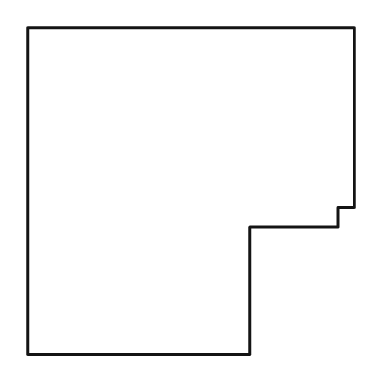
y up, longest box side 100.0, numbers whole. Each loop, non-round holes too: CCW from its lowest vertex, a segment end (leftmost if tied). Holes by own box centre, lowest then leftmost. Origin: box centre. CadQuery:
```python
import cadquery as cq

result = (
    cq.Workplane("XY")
    .moveTo(-50.0, -50.0)
    .lineTo(18.0, -50.0)
    .lineTo(18.0, -11.0)
    .lineTo(45.0, -11.0)
    .lineTo(45.0, -5.0)
    .lineTo(50.0, -5.0)
    .lineTo(50.0, 50.0)
    .lineTo(-50.0, 50.0)
    .close()
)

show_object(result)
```